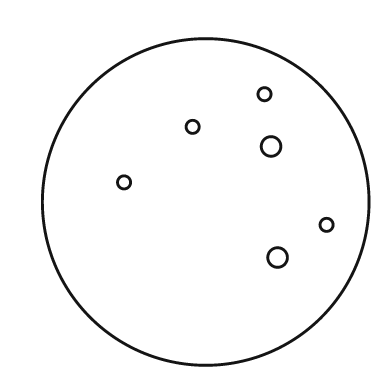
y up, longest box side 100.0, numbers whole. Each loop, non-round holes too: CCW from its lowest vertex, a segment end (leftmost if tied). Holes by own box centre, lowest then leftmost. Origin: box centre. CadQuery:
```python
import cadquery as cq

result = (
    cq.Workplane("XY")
    .moveTo(0.0, 0.0)
    .circle(50.0)
    .moveTo(22.0, -17.0)
    .circle(3.0)
    .moveTo(37.0, -7.0)
    .circle(2.0)
    .moveTo(-25.0, 6.0)
    .circle(2.0)
    .moveTo(20.0, 17.0)
    .circle(3.0)
    .moveTo(-4.0, 23.0)
    .circle(2.0)
    .moveTo(18.0, 33.0)
    .circle(2.0)
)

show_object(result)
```